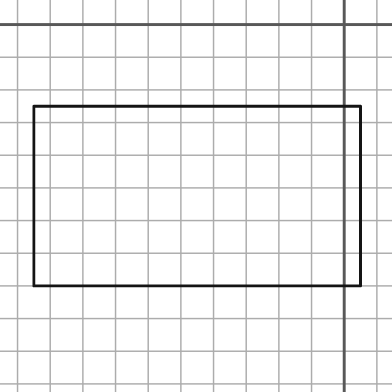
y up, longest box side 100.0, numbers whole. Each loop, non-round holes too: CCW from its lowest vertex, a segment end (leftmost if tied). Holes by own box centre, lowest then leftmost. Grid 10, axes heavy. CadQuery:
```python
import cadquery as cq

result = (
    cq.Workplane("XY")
    .moveTo(-95.0, -80.0)
    .lineTo(5.0, -80.0)
    .lineTo(5.0, -25.0)
    .lineTo(-95.0, -25.0)
    .close()
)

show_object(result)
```